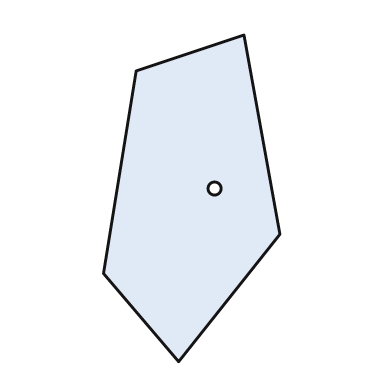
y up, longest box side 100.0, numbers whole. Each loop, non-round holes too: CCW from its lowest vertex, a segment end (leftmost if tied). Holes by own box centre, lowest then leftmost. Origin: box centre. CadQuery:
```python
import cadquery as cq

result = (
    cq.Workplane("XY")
    .moveTo(-4.0, -50.0)
    .lineTo(27.0, -11.0)
    .lineTo(16.0, 50.0)
    .lineTo(-17.0, 39.0)
    .lineTo(-27.0, -23.0)
    .close()
    .moveTo(7.0, 3.0)
    .circle(2.0)
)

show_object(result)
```